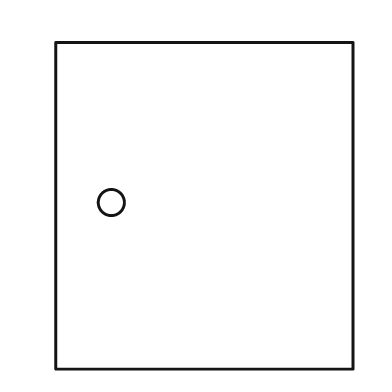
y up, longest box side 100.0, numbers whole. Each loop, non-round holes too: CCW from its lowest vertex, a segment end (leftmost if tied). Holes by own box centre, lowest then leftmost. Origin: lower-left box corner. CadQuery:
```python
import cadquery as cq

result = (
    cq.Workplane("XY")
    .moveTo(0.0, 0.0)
    .lineTo(91.0, 0.0)
    .lineTo(91.0, 100.0)
    .lineTo(0.0, 100.0)
    .close()
    .moveTo(17.0, 51.0)
    .circle(4.0)
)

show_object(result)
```